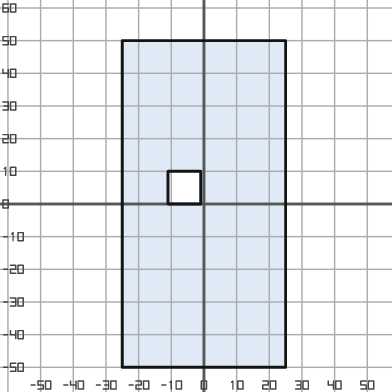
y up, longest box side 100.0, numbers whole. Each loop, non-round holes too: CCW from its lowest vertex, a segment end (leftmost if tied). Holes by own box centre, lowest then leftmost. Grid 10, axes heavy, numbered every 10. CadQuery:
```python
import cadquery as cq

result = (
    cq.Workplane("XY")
    .moveTo(-25.0, -50.0)
    .lineTo(25.0, -50.0)
    .lineTo(25.0, 50.0)
    .lineTo(-25.0, 50.0)
    .close()
    .moveTo(-11.0, 0.0)
    .lineTo(-1.0, 0.0)
    .lineTo(-1.0, 10.0)
    .lineTo(-11.0, 10.0)
    .close()
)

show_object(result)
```